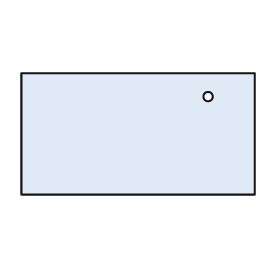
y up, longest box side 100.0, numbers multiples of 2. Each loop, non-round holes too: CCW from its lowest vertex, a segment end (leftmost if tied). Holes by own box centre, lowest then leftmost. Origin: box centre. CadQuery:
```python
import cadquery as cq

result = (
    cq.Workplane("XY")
    .moveTo(-50.0, -26.0)
    .lineTo(50.0, -26.0)
    .lineTo(50.0, 26.0)
    .lineTo(-50.0, 26.0)
    .close()
    .moveTo(30.0, 16.0)
    .circle(2.0)
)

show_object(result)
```